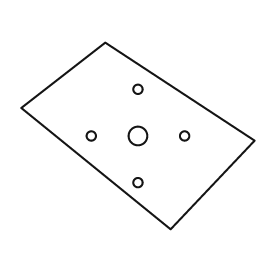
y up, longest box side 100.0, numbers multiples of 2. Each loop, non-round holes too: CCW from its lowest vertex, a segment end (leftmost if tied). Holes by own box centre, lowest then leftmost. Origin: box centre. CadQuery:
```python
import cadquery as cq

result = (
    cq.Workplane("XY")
    .moveTo(14.0, -40.0)
    .lineTo(50.0, -2.0)
    .lineTo(-14.0, 40.0)
    .lineTo(-50.0, 12.0)
    .close()
    .moveTo(0.0, -20.0)
    .circle(2.0)
    .moveTo(-20.0, 0.0)
    .circle(2.0)
    .moveTo(0.0, 0.0)
    .circle(4.0)
    .moveTo(20.0, 0.0)
    .circle(2.0)
    .moveTo(0.0, 20.0)
    .circle(2.0)
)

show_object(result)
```